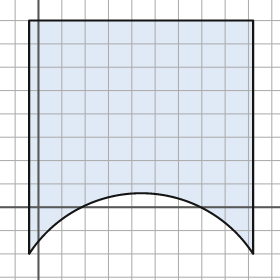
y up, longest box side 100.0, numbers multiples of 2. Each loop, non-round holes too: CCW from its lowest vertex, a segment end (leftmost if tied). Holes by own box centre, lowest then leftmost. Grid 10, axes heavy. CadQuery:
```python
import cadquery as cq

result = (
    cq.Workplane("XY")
    .moveTo(-4.0, -20.0)
    .threePointArc((44.0, 6.0), (92.0, -20.0))
    .lineTo(92.0, 80.0)
    .lineTo(-4.0, 80.0)
    .close()
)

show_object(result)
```